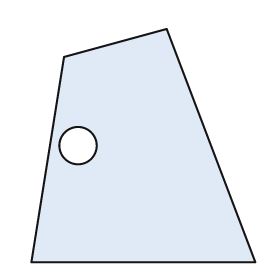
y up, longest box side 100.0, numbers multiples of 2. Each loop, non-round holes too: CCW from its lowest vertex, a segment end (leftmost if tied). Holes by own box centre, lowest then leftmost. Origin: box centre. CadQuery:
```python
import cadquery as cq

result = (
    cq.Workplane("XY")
    .moveTo(-48.0, -50.0)
    .lineTo(48.0, -50.0)
    .lineTo(10.0, 50.0)
    .lineTo(-34.0, 38.0)
    .close()
    .moveTo(-28.0, 0.0)
    .circle(8.0)
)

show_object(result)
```